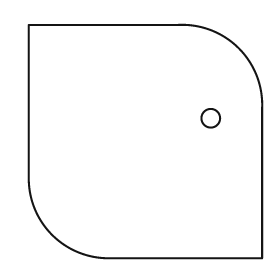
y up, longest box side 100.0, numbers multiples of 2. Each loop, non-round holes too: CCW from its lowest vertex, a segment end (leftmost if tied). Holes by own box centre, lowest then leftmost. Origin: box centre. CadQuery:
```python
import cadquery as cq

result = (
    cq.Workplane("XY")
    .moveTo(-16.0, -50.0)
    .lineTo(50.0, -50.0)
    .lineTo(50.0, 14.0)
    .threePointArc((40.0, 40.0), (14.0, 50.0))
    .lineTo(-50.0, 50.0)
    .lineTo(-50.0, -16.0)
    .threePointArc((-40.0, -40.0), (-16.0, -50.0))
    .close()
    .moveTo(28.0, 10.0)
    .circle(4.0)
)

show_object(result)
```